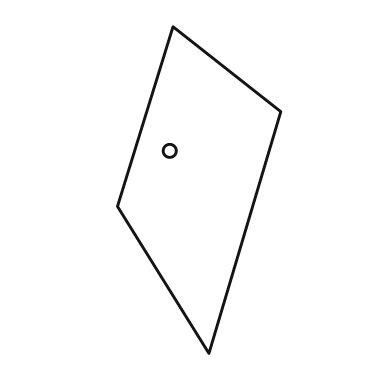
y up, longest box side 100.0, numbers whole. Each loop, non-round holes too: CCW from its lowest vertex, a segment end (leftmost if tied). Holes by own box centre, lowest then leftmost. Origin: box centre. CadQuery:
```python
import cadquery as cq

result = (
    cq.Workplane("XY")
    .moveTo(3.0, -50.0)
    .lineTo(25.0, 24.0)
    .lineTo(-8.0, 50.0)
    .lineTo(-25.0, -5.0)
    .close()
    .moveTo(-9.0, 12.0)
    .circle(2.0)
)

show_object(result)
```